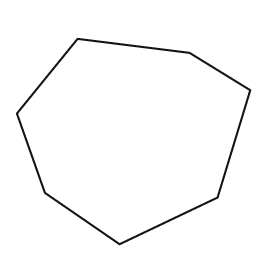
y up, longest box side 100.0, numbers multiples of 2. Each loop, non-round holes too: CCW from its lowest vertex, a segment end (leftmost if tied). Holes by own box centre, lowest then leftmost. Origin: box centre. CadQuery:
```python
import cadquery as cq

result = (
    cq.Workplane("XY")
    .moveTo(-6.0, -44.0)
    .lineTo(36.0, -24.0)
    .lineTo(50.0, 22.0)
    .lineTo(24.0, 38.0)
    .lineTo(-24.0, 44.0)
    .lineTo(-50.0, 12.0)
    .lineTo(-38.0, -22.0)
    .close()
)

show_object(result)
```